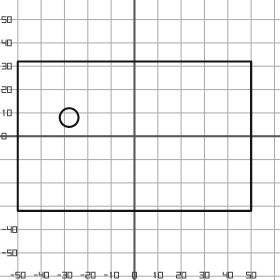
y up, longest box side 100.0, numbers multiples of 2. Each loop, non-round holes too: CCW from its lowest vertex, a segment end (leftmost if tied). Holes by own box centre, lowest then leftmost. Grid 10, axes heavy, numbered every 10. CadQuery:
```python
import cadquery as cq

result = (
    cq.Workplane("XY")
    .moveTo(-50.0, -32.0)
    .lineTo(50.0, -32.0)
    .lineTo(50.0, 32.0)
    .lineTo(-50.0, 32.0)
    .close()
    .moveTo(-28.0, 8.0)
    .circle(4.0)
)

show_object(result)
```